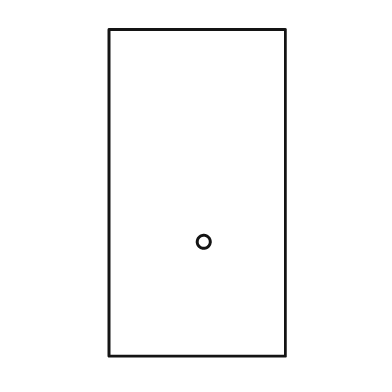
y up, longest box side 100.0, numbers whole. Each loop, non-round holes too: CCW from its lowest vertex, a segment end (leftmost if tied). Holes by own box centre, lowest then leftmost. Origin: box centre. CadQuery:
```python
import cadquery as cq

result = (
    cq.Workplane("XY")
    .moveTo(-27.0, -50.0)
    .lineTo(27.0, -50.0)
    .lineTo(27.0, 50.0)
    .lineTo(-27.0, 50.0)
    .close()
    .moveTo(2.0, -15.0)
    .circle(2.0)
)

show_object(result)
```